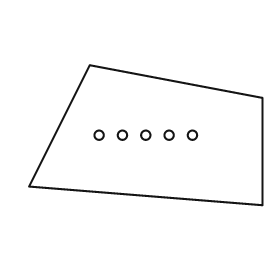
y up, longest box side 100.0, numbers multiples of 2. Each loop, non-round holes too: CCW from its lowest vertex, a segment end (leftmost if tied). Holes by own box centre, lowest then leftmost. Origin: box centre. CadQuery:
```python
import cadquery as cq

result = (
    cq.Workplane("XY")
    .moveTo(50.0, -30.0)
    .lineTo(50.0, 16.0)
    .lineTo(-24.0, 30.0)
    .lineTo(-50.0, -22.0)
    .close()
    .moveTo(-20.0, 0.0)
    .circle(2.0)
    .moveTo(-10.0, 0.0)
    .circle(2.0)
    .moveTo(0.0, 0.0)
    .circle(2.0)
    .moveTo(10.0, 0.0)
    .circle(2.0)
    .moveTo(20.0, 0.0)
    .circle(2.0)
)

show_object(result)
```